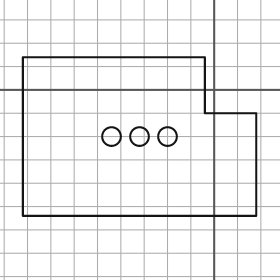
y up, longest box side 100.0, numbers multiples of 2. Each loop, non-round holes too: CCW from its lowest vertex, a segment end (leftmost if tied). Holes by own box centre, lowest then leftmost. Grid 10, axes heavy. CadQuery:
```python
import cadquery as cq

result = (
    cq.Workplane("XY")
    .moveTo(-82.0, -54.0)
    .lineTo(18.0, -54.0)
    .lineTo(18.0, -10.0)
    .lineTo(-4.0, -10.0)
    .lineTo(-4.0, 14.0)
    .lineTo(-82.0, 14.0)
    .close()
    .moveTo(-44.0, -20.0)
    .circle(4.0)
    .moveTo(-32.0, -20.0)
    .circle(4.0)
    .moveTo(-20.0, -20.0)
    .circle(4.0)
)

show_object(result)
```